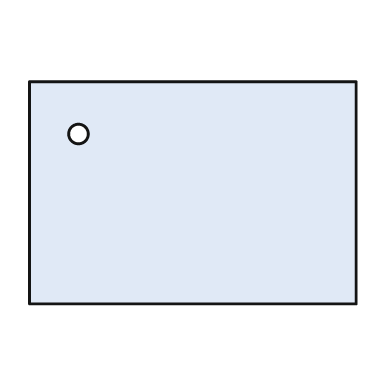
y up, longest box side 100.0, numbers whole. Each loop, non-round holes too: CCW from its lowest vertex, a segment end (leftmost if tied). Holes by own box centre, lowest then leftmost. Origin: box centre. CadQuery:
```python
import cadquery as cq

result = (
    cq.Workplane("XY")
    .moveTo(-50.0, -34.0)
    .lineTo(50.0, -34.0)
    .lineTo(50.0, 34.0)
    .lineTo(-50.0, 34.0)
    .close()
    .moveTo(-35.0, 18.0)
    .circle(3.0)
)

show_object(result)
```